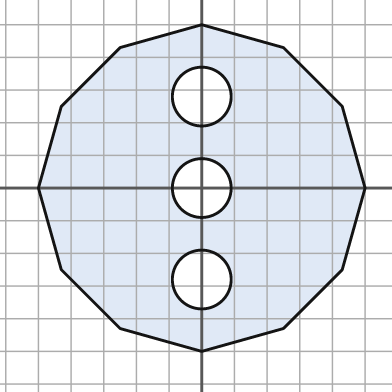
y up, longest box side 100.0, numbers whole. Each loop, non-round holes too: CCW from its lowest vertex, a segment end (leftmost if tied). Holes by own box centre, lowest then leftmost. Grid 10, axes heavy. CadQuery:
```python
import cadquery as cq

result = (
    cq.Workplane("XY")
    .moveTo(0.0, -50.0)
    .lineTo(25.0, -43.0)
    .lineTo(43.0, -25.0)
    .lineTo(50.0, 0.0)
    .lineTo(43.0, 25.0)
    .lineTo(25.0, 43.0)
    .lineTo(0.0, 50.0)
    .lineTo(-25.0, 43.0)
    .lineTo(-43.0, 25.0)
    .lineTo(-50.0, 0.0)
    .lineTo(-43.0, -25.0)
    .lineTo(-25.0, -43.0)
    .close()
    .moveTo(0.0, -28.0)
    .circle(9.0)
    .moveTo(0.0, 0.0)
    .circle(9.0)
    .moveTo(0.0, 28.0)
    .circle(9.0)
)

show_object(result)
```